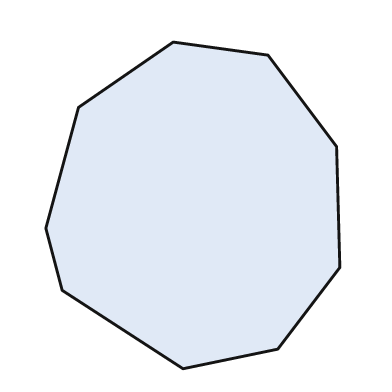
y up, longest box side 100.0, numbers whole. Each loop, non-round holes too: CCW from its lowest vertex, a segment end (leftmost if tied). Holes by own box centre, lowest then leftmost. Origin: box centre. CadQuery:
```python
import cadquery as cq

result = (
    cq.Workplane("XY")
    .moveTo(-3.0, -50.0)
    .lineTo(26.0, -44.0)
    .lineTo(45.0, -19.0)
    .lineTo(44.0, 18.0)
    .lineTo(23.0, 46.0)
    .lineTo(-6.0, 50.0)
    .lineTo(-35.0, 30.0)
    .lineTo(-45.0, -7.0)
    .lineTo(-40.0, -26.0)
    .close()
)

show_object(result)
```